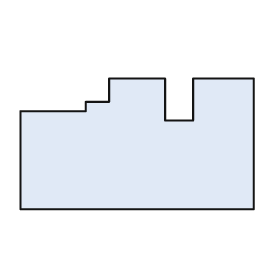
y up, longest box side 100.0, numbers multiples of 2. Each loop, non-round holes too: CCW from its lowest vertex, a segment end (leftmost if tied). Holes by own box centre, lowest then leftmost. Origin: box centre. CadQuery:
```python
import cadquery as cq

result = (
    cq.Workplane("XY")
    .moveTo(-50.0, -28.0)
    .lineTo(50.0, -28.0)
    .lineTo(50.0, 28.0)
    .lineTo(24.0, 28.0)
    .lineTo(24.0, 10.0)
    .lineTo(12.0, 10.0)
    .lineTo(12.0, 28.0)
    .lineTo(-12.0, 28.0)
    .lineTo(-12.0, 18.0)
    .lineTo(-22.0, 18.0)
    .lineTo(-22.0, 14.0)
    .lineTo(-50.0, 14.0)
    .close()
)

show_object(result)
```